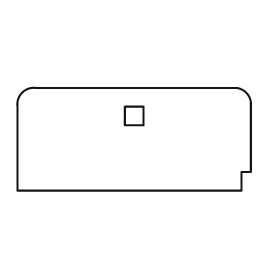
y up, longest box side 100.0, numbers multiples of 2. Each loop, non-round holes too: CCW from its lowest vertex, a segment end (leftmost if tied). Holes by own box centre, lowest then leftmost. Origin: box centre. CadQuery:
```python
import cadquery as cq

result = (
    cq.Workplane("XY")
    .moveTo(-50.0, -22.0)
    .lineTo(46.0, -22.0)
    .lineTo(46.0, -14.0)
    .lineTo(50.0, -14.0)
    .lineTo(50.0, 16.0)
    .threePointArc((48.0, 20.0), (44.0, 22.0))
    .lineTo(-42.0, 22.0)
    .threePointArc((-48.0, 20.0), (-50.0, 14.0))
    .close()
    .moveTo(-4.0, 6.0)
    .lineTo(4.0, 6.0)
    .lineTo(4.0, 14.0)
    .lineTo(-4.0, 14.0)
    .close()
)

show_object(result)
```